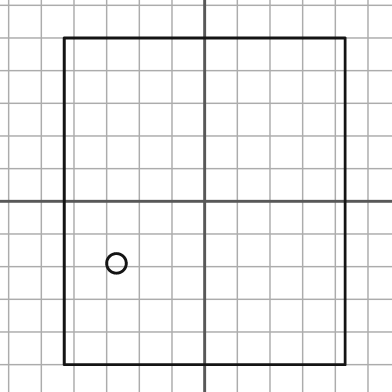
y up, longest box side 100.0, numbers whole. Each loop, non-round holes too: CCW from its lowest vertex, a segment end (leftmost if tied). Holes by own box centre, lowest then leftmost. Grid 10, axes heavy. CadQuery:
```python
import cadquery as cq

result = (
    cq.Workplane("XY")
    .moveTo(-43.0, -50.0)
    .lineTo(43.0, -50.0)
    .lineTo(43.0, 50.0)
    .lineTo(-43.0, 50.0)
    .close()
    .moveTo(-27.0, -19.0)
    .circle(3.0)
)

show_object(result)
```